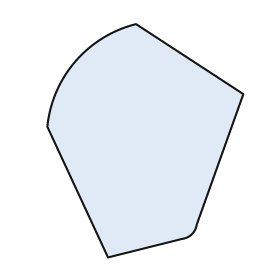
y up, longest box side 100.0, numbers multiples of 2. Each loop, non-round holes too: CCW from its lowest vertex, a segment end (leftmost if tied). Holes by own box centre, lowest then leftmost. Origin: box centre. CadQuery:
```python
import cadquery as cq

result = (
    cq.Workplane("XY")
    .moveTo(-16.0, -50.0)
    .lineTo(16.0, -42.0)
    .threePointArc((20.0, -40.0), (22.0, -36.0))
    .lineTo(42.0, 20.0)
    .lineTo(-4.0, 50.0)
    .threePointArc((-30.0, 34.0), (-42.0, 6.0))
    .close()
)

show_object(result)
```